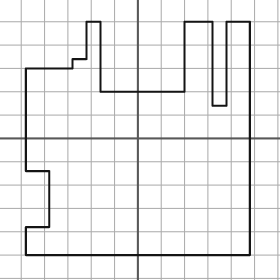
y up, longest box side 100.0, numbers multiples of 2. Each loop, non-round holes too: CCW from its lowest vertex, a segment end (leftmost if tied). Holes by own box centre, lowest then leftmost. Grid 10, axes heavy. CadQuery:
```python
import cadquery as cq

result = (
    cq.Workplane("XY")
    .moveTo(-48.0, -50.0)
    .lineTo(48.0, -50.0)
    .lineTo(48.0, 50.0)
    .lineTo(38.0, 50.0)
    .lineTo(38.0, 14.0)
    .lineTo(32.0, 14.0)
    .lineTo(32.0, 50.0)
    .lineTo(20.0, 50.0)
    .lineTo(20.0, 20.0)
    .lineTo(-16.0, 20.0)
    .lineTo(-16.0, 50.0)
    .lineTo(-22.0, 50.0)
    .lineTo(-22.0, 34.0)
    .lineTo(-28.0, 34.0)
    .lineTo(-28.0, 30.0)
    .lineTo(-48.0, 30.0)
    .lineTo(-48.0, -14.0)
    .lineTo(-38.0, -14.0)
    .lineTo(-38.0, -38.0)
    .lineTo(-48.0, -38.0)
    .close()
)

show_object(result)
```